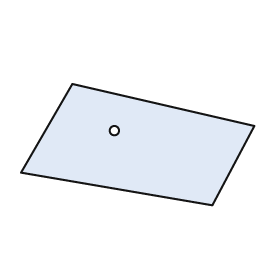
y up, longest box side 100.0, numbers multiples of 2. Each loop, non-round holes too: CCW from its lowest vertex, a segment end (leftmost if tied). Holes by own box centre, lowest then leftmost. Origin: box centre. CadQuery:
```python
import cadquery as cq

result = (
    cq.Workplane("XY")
    .moveTo(32.0, -26.0)
    .lineTo(50.0, 8.0)
    .lineTo(-28.0, 26.0)
    .lineTo(-50.0, -12.0)
    .close()
    .moveTo(-10.0, 6.0)
    .circle(2.0)
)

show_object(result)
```